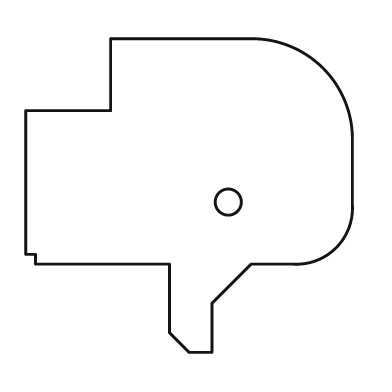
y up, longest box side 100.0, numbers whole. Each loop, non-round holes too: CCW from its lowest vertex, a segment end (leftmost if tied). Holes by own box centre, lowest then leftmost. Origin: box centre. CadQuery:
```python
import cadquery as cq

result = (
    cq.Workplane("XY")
    .moveTo(0.0, -48.0)
    .lineTo(7.0, -48.0)
    .lineTo(7.0, -33.0)
    .lineTo(19.0, -21.0)
    .lineTo(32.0, -21.0)
    .threePointArc((45.0, -16.0), (50.0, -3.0))
    .lineTo(50.0, 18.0)
    .threePointArc((41.0, 39.0), (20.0, 48.0))
    .lineTo(-24.0, 48.0)
    .lineTo(-24.0, 26.0)
    .lineTo(-50.0, 26.0)
    .lineTo(-50.0, -18.0)
    .lineTo(-47.0, -18.0)
    .lineTo(-47.0, -21.0)
    .lineTo(-6.0, -21.0)
    .lineTo(-6.0, -42.0)
    .close()
    .moveTo(12.0, -2.0)
    .circle(4.0)
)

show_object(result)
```